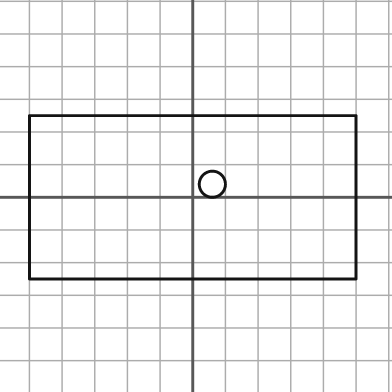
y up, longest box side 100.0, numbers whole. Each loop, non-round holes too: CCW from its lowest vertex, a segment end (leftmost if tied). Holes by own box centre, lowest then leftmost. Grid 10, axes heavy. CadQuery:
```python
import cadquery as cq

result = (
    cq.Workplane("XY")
    .moveTo(-50.0, -25.0)
    .lineTo(50.0, -25.0)
    .lineTo(50.0, 25.0)
    .lineTo(-50.0, 25.0)
    .close()
    .moveTo(6.0, 4.0)
    .circle(4.0)
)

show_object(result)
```